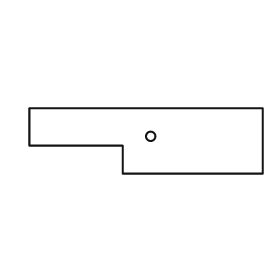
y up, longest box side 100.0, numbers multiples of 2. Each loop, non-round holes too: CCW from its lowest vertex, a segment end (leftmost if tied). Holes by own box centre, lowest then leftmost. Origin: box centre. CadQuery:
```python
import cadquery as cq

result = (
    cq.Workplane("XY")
    .moveTo(-10.0, -14.0)
    .lineTo(50.0, -14.0)
    .lineTo(50.0, 14.0)
    .lineTo(-50.0, 14.0)
    .lineTo(-50.0, -2.0)
    .lineTo(-10.0, -2.0)
    .close()
    .moveTo(2.0, 2.0)
    .circle(2.0)
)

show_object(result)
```